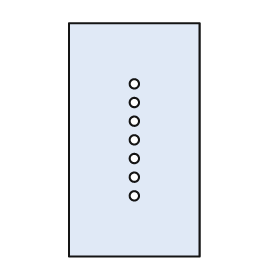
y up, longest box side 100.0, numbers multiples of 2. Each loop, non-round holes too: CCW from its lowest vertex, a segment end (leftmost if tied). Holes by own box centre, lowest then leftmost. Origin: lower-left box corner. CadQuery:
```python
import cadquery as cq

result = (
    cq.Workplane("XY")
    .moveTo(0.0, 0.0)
    .lineTo(56.0, 0.0)
    .lineTo(56.0, 100.0)
    .lineTo(0.0, 100.0)
    .close()
    .moveTo(28.0, 26.0)
    .circle(2.0)
    .moveTo(28.0, 34.0)
    .circle(2.0)
    .moveTo(28.0, 42.0)
    .circle(2.0)
    .moveTo(28.0, 50.0)
    .circle(2.0)
    .moveTo(28.0, 58.0)
    .circle(2.0)
    .moveTo(28.0, 66.0)
    .circle(2.0)
    .moveTo(28.0, 74.0)
    .circle(2.0)
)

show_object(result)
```